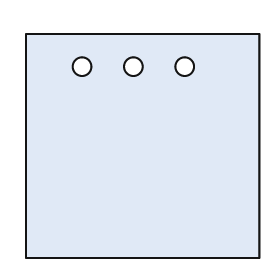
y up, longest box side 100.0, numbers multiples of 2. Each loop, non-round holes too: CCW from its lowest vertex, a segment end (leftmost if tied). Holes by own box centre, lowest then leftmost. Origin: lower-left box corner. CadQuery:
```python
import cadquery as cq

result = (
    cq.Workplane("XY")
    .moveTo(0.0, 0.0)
    .lineTo(100.0, 0.0)
    .lineTo(100.0, 96.0)
    .lineTo(0.0, 96.0)
    .close()
    .moveTo(24.0, 82.0)
    .circle(4.0)
    .moveTo(46.0, 82.0)
    .circle(4.0)
    .moveTo(68.0, 82.0)
    .circle(4.0)
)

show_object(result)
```